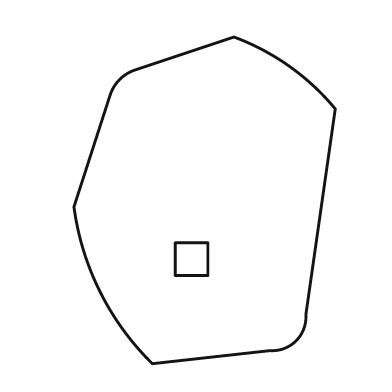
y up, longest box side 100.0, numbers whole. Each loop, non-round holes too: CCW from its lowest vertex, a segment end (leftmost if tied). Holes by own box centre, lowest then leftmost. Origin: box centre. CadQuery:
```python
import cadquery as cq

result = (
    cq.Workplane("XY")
    .moveTo(-16.0, -50.0)
    .lineTo(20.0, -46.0)
    .threePointArc((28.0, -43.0), (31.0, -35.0))
    .lineTo(40.0, 28.0)
    .threePointArc((26.0, 41.0), (9.0, 50.0))
    .lineTo(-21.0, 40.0)
    .threePointArc((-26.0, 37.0), (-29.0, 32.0))
    .lineTo(-40.0, -2.0)
    .threePointArc((-32.0, -28.0), (-16.0, -50.0))
    .close()
    .moveTo(-9.0, -23.0)
    .lineTo(1.0, -23.0)
    .lineTo(1.0, -13.0)
    .lineTo(-9.0, -13.0)
    .close()
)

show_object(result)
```